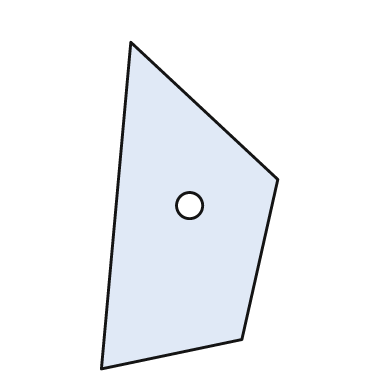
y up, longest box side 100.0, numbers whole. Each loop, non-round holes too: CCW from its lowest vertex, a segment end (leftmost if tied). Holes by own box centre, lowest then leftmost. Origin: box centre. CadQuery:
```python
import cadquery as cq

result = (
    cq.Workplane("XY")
    .moveTo(-27.0, -50.0)
    .lineTo(16.0, -41.0)
    .lineTo(27.0, 8.0)
    .lineTo(-18.0, 50.0)
    .close()
    .moveTo(0.0, 0.0)
    .circle(4.0)
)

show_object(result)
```